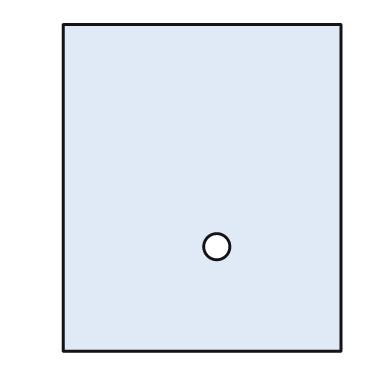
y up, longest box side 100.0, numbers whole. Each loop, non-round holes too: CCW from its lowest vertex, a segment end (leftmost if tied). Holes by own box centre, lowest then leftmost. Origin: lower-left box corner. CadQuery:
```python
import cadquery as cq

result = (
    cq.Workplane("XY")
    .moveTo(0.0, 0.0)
    .lineTo(85.0, 0.0)
    .lineTo(85.0, 100.0)
    .lineTo(0.0, 100.0)
    .close()
    .moveTo(47.0, 32.0)
    .circle(4.0)
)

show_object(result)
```